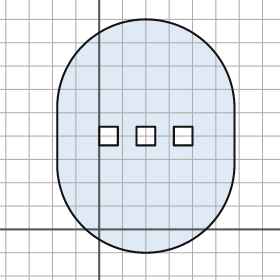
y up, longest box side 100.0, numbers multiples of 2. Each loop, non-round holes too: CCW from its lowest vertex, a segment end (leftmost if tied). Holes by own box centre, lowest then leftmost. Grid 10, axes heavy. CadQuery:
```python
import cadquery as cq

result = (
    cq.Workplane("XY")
    .moveTo(-18.0, 28.0)
    .threePointArc((20.0, -10.0), (58.0, 28.0))
    .lineTo(58.0, 52.0)
    .threePointArc((20.0, 90.0), (-18.0, 52.0))
    .close()
    .moveTo(0.0, 36.0)
    .lineTo(8.0, 36.0)
    .lineTo(8.0, 44.0)
    .lineTo(0.0, 44.0)
    .close()
    .moveTo(16.0, 36.0)
    .lineTo(24.0, 36.0)
    .lineTo(24.0, 44.0)
    .lineTo(16.0, 44.0)
    .close()
    .moveTo(32.0, 36.0)
    .lineTo(40.0, 36.0)
    .lineTo(40.0, 44.0)
    .lineTo(32.0, 44.0)
    .close()
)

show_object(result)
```